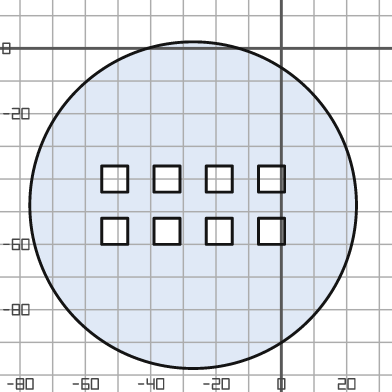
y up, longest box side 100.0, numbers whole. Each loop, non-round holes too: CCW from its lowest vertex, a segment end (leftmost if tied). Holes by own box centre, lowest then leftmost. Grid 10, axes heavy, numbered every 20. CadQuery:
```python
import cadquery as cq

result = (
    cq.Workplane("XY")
    .moveTo(-27.0, -48.0)
    .circle(50.0)
    .moveTo(-55.0, -60.0)
    .lineTo(-47.0, -60.0)
    .lineTo(-47.0, -52.0)
    .lineTo(-55.0, -52.0)
    .close()
    .moveTo(-39.0, -60.0)
    .lineTo(-31.0, -60.0)
    .lineTo(-31.0, -52.0)
    .lineTo(-39.0, -52.0)
    .close()
    .moveTo(-23.0, -60.0)
    .lineTo(-15.0, -60.0)
    .lineTo(-15.0, -52.0)
    .lineTo(-23.0, -52.0)
    .close()
    .moveTo(-7.0, -60.0)
    .lineTo(1.0, -60.0)
    .lineTo(1.0, -52.0)
    .lineTo(-7.0, -52.0)
    .close()
    .moveTo(-55.0, -44.0)
    .lineTo(-47.0, -44.0)
    .lineTo(-47.0, -36.0)
    .lineTo(-55.0, -36.0)
    .close()
    .moveTo(-39.0, -44.0)
    .lineTo(-31.0, -44.0)
    .lineTo(-31.0, -36.0)
    .lineTo(-39.0, -36.0)
    .close()
    .moveTo(-23.0, -44.0)
    .lineTo(-15.0, -44.0)
    .lineTo(-15.0, -36.0)
    .lineTo(-23.0, -36.0)
    .close()
    .moveTo(-7.0, -44.0)
    .lineTo(1.0, -44.0)
    .lineTo(1.0, -36.0)
    .lineTo(-7.0, -36.0)
    .close()
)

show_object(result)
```